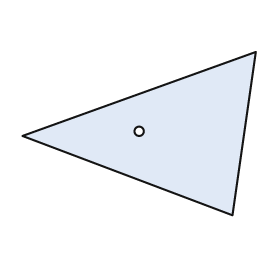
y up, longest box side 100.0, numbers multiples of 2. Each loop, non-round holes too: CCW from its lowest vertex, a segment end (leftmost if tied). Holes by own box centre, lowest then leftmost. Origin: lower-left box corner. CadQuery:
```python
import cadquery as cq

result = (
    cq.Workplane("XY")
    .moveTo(90.0, 0.0)
    .lineTo(100.0, 70.0)
    .lineTo(0.0, 34.0)
    .close()
    .moveTo(50.0, 36.0)
    .circle(2.0)
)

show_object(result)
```